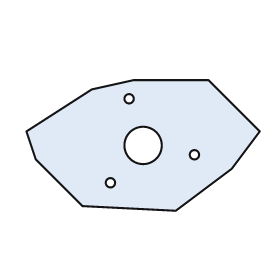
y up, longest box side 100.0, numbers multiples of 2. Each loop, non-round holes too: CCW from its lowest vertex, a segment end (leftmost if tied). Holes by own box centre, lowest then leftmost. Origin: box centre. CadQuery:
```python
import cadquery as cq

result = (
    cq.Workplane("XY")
    .moveTo(14.0, -28.0)
    .lineTo(38.0, -10.0)
    .lineTo(50.0, 6.0)
    .lineTo(28.0, 28.0)
    .lineTo(-4.0, 28.0)
    .lineTo(-22.0, 24.0)
    .lineTo(-50.0, 6.0)
    .lineTo(-46.0, -6.0)
    .lineTo(-26.0, -26.0)
    .close()
    .moveTo(-14.0, -16.0)
    .circle(2.0)
    .moveTo(22.0, -4.0)
    .circle(2.0)
    .moveTo(0.0, 0.0)
    .circle(8.0)
    .moveTo(-6.0, 20.0)
    .circle(2.0)
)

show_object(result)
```